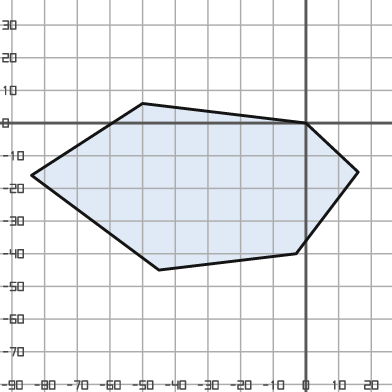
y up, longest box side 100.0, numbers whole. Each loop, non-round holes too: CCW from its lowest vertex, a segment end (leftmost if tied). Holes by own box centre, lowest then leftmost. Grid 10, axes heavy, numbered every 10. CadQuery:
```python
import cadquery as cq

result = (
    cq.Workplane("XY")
    .moveTo(-45.0, -45.0)
    .lineTo(-3.0, -40.0)
    .lineTo(16.0, -15.0)
    .lineTo(0.0, 0.0)
    .lineTo(-50.0, 6.0)
    .lineTo(-84.0, -16.0)
    .close()
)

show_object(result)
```